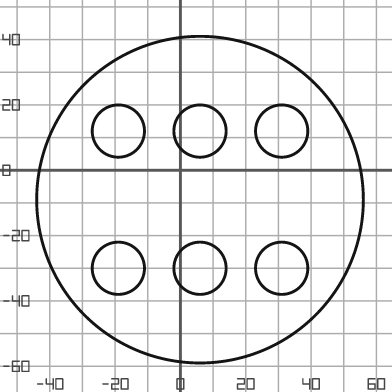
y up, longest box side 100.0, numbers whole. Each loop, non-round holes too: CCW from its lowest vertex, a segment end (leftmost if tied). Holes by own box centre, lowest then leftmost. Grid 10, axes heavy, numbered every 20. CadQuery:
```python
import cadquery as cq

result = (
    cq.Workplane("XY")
    .moveTo(6.0, -9.0)
    .circle(50.0)
    .moveTo(-19.0, -30.0)
    .circle(8.0)
    .moveTo(6.0, -30.0)
    .circle(8.0)
    .moveTo(31.0, -30.0)
    .circle(8.0)
    .moveTo(-19.0, 12.0)
    .circle(8.0)
    .moveTo(6.0, 12.0)
    .circle(8.0)
    .moveTo(31.0, 12.0)
    .circle(8.0)
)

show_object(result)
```